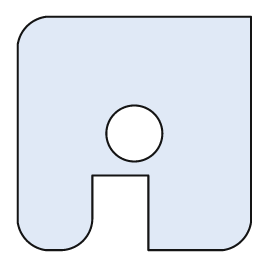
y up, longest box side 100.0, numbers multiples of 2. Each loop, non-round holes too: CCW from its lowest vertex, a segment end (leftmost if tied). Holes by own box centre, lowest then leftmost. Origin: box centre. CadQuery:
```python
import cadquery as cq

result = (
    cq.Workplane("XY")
    .moveTo(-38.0, -50.0)
    .lineTo(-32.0, -50.0)
    .threePointArc((-22.0, -46.0), (-18.0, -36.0))
    .lineTo(-18.0, -18.0)
    .lineTo(6.0, -18.0)
    .lineTo(6.0, -50.0)
    .lineTo(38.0, -50.0)
    .threePointArc((46.0, -46.0), (50.0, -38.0))
    .lineTo(50.0, 50.0)
    .lineTo(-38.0, 50.0)
    .threePointArc((-46.0, 46.0), (-50.0, 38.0))
    .lineTo(-50.0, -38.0)
    .threePointArc((-46.0, -46.0), (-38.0, -50.0))
    .close()
    .moveTo(0.0, 0.0)
    .circle(12.0)
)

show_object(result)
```